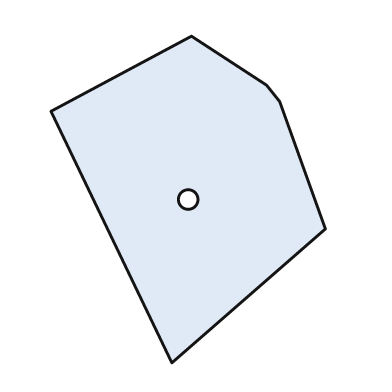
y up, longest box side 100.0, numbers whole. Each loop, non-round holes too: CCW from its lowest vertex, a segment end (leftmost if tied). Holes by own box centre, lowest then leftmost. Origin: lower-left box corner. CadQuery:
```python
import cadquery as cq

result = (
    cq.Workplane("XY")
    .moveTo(37.0, 0.0)
    .lineTo(84.0, 41.0)
    .lineTo(70.0, 80.0)
    .lineTo(66.0, 85.0)
    .lineTo(43.0, 100.0)
    .lineTo(0.0, 77.0)
    .close()
    .moveTo(42.0, 50.0)
    .circle(3.0)
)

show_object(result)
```